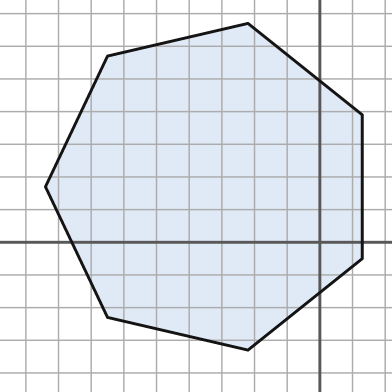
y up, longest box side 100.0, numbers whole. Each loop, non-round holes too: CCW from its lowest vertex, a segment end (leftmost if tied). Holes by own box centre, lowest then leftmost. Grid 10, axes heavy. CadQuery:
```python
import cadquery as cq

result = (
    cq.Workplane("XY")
    .moveTo(-22.0, -33.0)
    .lineTo(13.0, -5.0)
    .lineTo(13.0, 39.0)
    .lineTo(-22.0, 67.0)
    .lineTo(-65.0, 57.0)
    .lineTo(-84.0, 17.0)
    .lineTo(-65.0, -23.0)
    .close()
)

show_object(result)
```